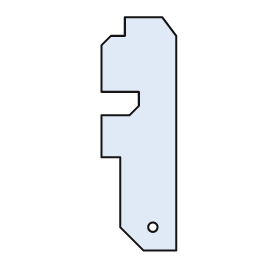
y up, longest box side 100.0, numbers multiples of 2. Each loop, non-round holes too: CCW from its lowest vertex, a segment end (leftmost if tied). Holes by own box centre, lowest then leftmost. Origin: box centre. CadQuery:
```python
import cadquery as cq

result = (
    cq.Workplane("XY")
    .moveTo(2.0, -50.0)
    .lineTo(16.0, -50.0)
    .lineTo(16.0, 42.0)
    .lineTo(10.0, 50.0)
    .lineTo(-6.0, 50.0)
    .lineTo(-6.0, 42.0)
    .lineTo(-12.0, 42.0)
    .lineTo(-16.0, 38.0)
    .lineTo(-16.0, 18.0)
    .lineTo(0.0, 18.0)
    .lineTo(0.0, 12.0)
    .lineTo(-4.0, 8.0)
    .lineTo(-16.0, 8.0)
    .lineTo(-16.0, -10.0)
    .lineTo(-8.0, -10.0)
    .lineTo(-8.0, -40.0)
    .close()
    .moveTo(6.0, -40.0)
    .circle(2.0)
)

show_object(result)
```